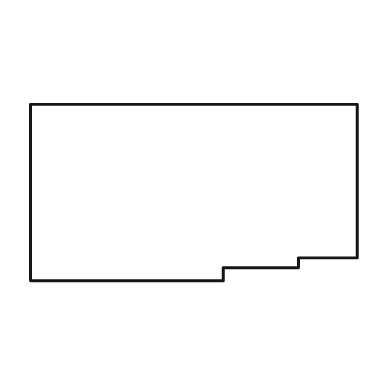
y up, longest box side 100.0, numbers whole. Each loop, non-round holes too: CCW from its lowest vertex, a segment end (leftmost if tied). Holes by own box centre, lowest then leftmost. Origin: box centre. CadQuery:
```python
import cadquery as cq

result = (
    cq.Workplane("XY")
    .moveTo(-50.0, -27.0)
    .lineTo(9.0, -27.0)
    .lineTo(9.0, -23.0)
    .lineTo(32.0, -23.0)
    .lineTo(32.0, -20.0)
    .lineTo(50.0, -20.0)
    .lineTo(50.0, 27.0)
    .lineTo(-50.0, 27.0)
    .close()
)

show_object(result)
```